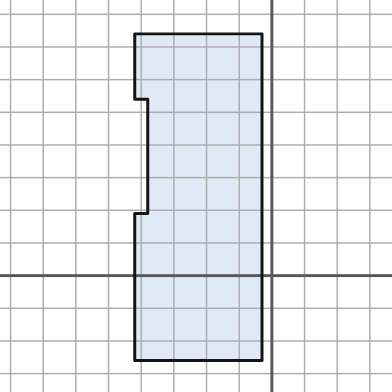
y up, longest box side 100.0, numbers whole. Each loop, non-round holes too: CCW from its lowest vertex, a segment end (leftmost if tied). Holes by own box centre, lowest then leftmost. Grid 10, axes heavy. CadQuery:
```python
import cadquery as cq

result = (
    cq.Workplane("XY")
    .moveTo(-42.0, -26.0)
    .lineTo(-3.0, -26.0)
    .lineTo(-3.0, 74.0)
    .lineTo(-42.0, 74.0)
    .lineTo(-42.0, 54.0)
    .lineTo(-38.0, 54.0)
    .lineTo(-38.0, 19.0)
    .lineTo(-42.0, 19.0)
    .close()
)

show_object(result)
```